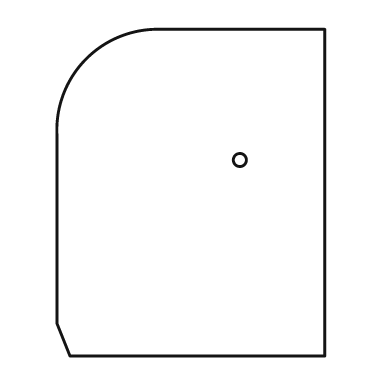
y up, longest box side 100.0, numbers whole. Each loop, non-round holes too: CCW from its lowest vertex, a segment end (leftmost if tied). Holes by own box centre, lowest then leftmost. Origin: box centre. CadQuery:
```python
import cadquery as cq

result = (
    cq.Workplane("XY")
    .moveTo(-37.0, -50.0)
    .lineTo(41.0, -50.0)
    .lineTo(41.0, 50.0)
    .lineTo(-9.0, 50.0)
    .threePointArc((-32.0, 41.0), (-41.0, 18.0))
    .lineTo(-41.0, -40.0)
    .close()
    .moveTo(15.0, 10.0)
    .circle(2.0)
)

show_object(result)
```